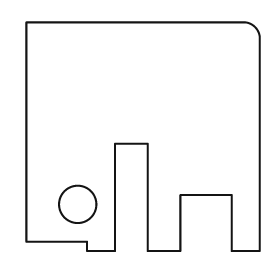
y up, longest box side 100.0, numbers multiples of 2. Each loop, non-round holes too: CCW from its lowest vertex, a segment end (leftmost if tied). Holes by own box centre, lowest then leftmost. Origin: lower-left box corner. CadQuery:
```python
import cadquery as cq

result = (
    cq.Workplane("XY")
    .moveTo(26.0, 0.0)
    .lineTo(38.0, 0.0)
    .lineTo(38.0, 46.0)
    .lineTo(52.0, 46.0)
    .lineTo(52.0, 0.0)
    .lineTo(66.0, 0.0)
    .lineTo(66.0, 24.0)
    .lineTo(88.0, 24.0)
    .lineTo(88.0, 0.0)
    .lineTo(100.0, 0.0)
    .lineTo(100.0, 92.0)
    .threePointArc((98.0, 96.0), (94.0, 98.0))
    .lineTo(0.0, 98.0)
    .lineTo(0.0, 4.0)
    .lineTo(26.0, 4.0)
    .close()
    .moveTo(22.0, 20.0)
    .circle(8.0)
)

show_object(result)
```